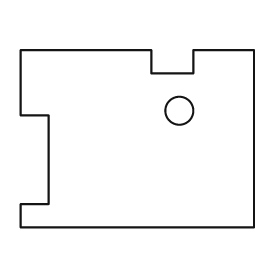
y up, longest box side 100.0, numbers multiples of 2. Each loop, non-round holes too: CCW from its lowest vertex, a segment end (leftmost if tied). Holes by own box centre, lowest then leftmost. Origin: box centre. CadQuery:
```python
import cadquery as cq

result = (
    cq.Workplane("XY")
    .moveTo(-50.0, -38.0)
    .lineTo(50.0, -38.0)
    .lineTo(50.0, 38.0)
    .lineTo(24.0, 38.0)
    .lineTo(24.0, 28.0)
    .lineTo(6.0, 28.0)
    .lineTo(6.0, 38.0)
    .lineTo(-50.0, 38.0)
    .lineTo(-50.0, 10.0)
    .lineTo(-38.0, 10.0)
    .lineTo(-38.0, -28.0)
    .lineTo(-50.0, -28.0)
    .close()
    .moveTo(18.0, 12.0)
    .circle(6.0)
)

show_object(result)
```